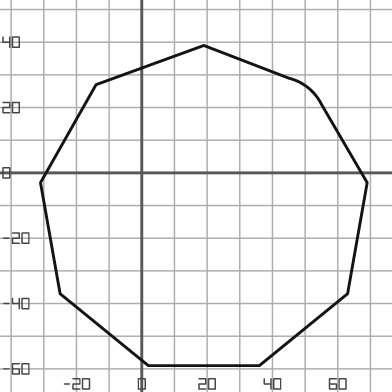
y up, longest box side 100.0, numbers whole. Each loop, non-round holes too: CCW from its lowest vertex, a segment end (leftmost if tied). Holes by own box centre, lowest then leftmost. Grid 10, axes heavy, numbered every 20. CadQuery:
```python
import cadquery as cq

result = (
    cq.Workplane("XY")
    .moveTo(2.0, -59.0)
    .lineTo(36.0, -59.0)
    .lineTo(63.0, -37.0)
    .lineTo(69.0, -3.0)
    .lineTo(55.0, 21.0)
    .threePointArc((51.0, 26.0), (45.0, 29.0))
    .lineTo(19.0, 39.0)
    .lineTo(-14.0, 27.0)
    .lineTo(-31.0, -3.0)
    .lineTo(-25.0, -37.0)
    .close()
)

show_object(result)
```